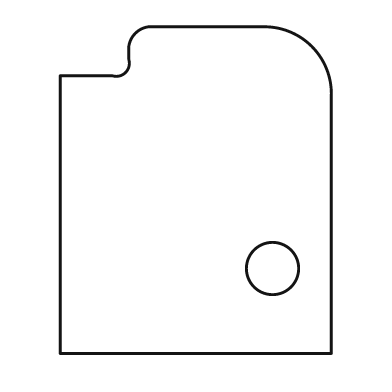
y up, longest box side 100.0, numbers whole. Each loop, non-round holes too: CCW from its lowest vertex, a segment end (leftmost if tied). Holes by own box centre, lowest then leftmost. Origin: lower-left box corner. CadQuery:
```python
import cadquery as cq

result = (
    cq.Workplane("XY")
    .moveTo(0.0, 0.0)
    .lineTo(83.0, 0.0)
    .lineTo(83.0, 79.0)
    .threePointArc((77.0, 94.0), (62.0, 100.0))
    .lineTo(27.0, 100.0)
    .threePointArc((23.0, 98.0), (21.0, 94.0))
    .lineTo(21.0, 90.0)
    .threePointArc((20.0, 86.0), (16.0, 85.0))
    .lineTo(0.0, 85.0)
    .close()
    .moveTo(65.0, 26.0)
    .circle(8.0)
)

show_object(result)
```